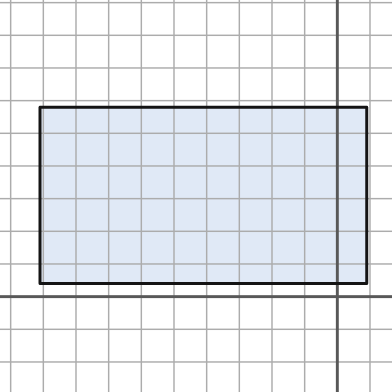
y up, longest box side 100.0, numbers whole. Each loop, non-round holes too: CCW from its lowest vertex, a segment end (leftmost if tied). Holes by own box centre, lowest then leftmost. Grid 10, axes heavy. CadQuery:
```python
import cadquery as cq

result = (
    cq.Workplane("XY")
    .moveTo(-91.0, 4.0)
    .lineTo(9.0, 4.0)
    .lineTo(9.0, 58.0)
    .lineTo(-91.0, 58.0)
    .close()
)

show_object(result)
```